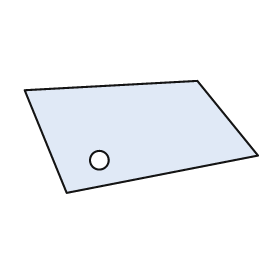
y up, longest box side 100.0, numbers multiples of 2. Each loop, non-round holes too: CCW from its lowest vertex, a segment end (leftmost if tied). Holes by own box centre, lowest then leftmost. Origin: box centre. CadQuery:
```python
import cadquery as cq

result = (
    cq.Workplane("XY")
    .moveTo(-32.0, -24.0)
    .lineTo(50.0, -8.0)
    .lineTo(24.0, 24.0)
    .lineTo(-50.0, 20.0)
    .close()
    .moveTo(-18.0, -10.0)
    .circle(4.0)
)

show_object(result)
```